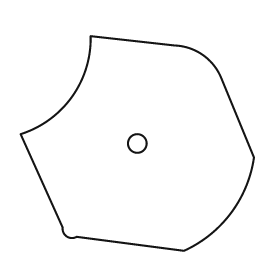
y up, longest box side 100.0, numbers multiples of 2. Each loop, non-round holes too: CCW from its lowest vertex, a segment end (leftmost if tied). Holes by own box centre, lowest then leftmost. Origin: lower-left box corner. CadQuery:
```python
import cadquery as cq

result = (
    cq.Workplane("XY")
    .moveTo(70.0, 0.0)
    .threePointArc((90.0, 16.0), (100.0, 40.0))
    .lineTo(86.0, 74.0)
    .threePointArc((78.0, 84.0), (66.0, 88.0))
    .lineTo(30.0, 92.0)
    .threePointArc((22.0, 66.0), (0.0, 50.0))
    .lineTo(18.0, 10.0)
    .threePointArc((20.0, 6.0), (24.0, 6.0))
    .close()
    .moveTo(50.0, 46.0)
    .circle(4.0)
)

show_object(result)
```